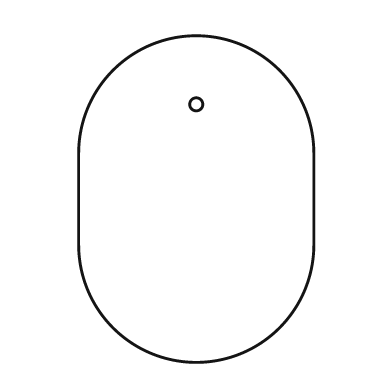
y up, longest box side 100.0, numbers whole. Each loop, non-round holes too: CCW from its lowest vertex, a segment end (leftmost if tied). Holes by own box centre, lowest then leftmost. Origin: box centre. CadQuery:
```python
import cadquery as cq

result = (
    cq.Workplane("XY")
    .moveTo(-36.0, -14.0)
    .threePointArc((0.0, -50.0), (36.0, -14.0))
    .lineTo(36.0, 14.0)
    .threePointArc((0.0, 50.0), (-36.0, 14.0))
    .close()
    .moveTo(0.0, 29.0)
    .circle(2.0)
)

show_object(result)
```